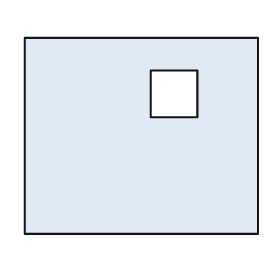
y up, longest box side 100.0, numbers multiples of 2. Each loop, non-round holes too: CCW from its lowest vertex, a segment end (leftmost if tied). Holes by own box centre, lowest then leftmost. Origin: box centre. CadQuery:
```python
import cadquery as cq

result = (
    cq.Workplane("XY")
    .moveTo(-50.0, -42.0)
    .lineTo(50.0, -42.0)
    .lineTo(50.0, 42.0)
    .lineTo(-50.0, 42.0)
    .close()
    .moveTo(4.0, 8.0)
    .lineTo(24.0, 8.0)
    .lineTo(24.0, 28.0)
    .lineTo(4.0, 28.0)
    .close()
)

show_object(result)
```